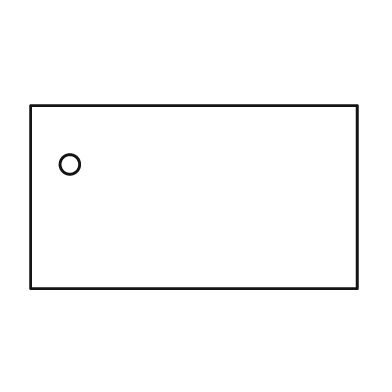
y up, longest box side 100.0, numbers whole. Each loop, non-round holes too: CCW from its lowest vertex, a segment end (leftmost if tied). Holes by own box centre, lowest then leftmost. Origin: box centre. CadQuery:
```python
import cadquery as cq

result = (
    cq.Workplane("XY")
    .moveTo(-50.0, -28.0)
    .lineTo(50.0, -28.0)
    .lineTo(50.0, 28.0)
    .lineTo(-50.0, 28.0)
    .close()
    .moveTo(-38.0, 10.0)
    .circle(3.0)
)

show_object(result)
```